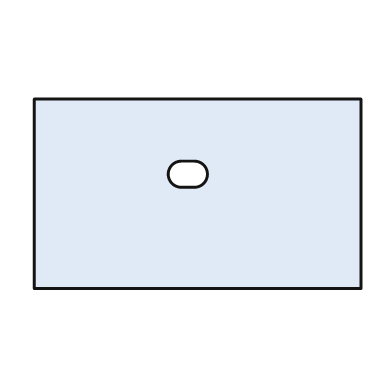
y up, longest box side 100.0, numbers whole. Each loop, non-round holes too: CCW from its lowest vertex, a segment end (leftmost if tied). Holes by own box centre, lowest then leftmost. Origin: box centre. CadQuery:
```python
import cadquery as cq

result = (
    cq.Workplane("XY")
    .moveTo(-50.0, -29.0)
    .lineTo(50.0, -29.0)
    .lineTo(50.0, 29.0)
    .lineTo(-50.0, 29.0)
    .close()
    .moveTo(-5.0, 2.0)
    .lineTo(-1.0, 2.0)
    .threePointArc((3.0, 6.0), (-1.0, 10.0))
    .lineTo(-5.0, 10.0)
    .threePointArc((-9.0, 6.0), (-5.0, 2.0))
    .close()
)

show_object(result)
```